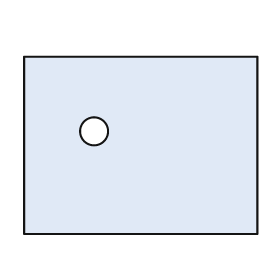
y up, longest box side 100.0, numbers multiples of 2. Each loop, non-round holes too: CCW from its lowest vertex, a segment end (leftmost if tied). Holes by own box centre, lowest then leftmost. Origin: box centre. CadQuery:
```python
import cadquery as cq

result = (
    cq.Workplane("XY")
    .moveTo(-50.0, -38.0)
    .lineTo(50.0, -38.0)
    .lineTo(50.0, 38.0)
    .lineTo(-50.0, 38.0)
    .close()
    .moveTo(-20.0, 6.0)
    .circle(6.0)
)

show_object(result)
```